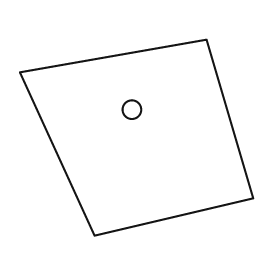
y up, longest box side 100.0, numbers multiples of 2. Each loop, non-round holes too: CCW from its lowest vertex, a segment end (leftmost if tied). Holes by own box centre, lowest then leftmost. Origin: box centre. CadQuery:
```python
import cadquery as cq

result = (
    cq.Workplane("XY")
    .moveTo(-18.0, -42.0)
    .lineTo(50.0, -26.0)
    .lineTo(30.0, 42.0)
    .lineTo(-50.0, 28.0)
    .close()
    .moveTo(-2.0, 12.0)
    .circle(4.0)
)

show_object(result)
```